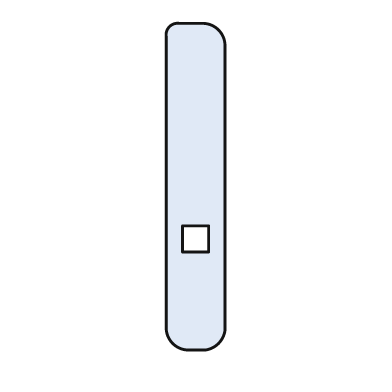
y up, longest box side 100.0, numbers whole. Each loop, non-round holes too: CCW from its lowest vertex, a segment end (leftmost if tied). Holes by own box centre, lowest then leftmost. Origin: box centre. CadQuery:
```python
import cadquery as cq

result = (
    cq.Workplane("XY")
    .moveTo(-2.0, -50.0)
    .lineTo(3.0, -50.0)
    .threePointArc((7.0, -48.0), (9.0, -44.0))
    .lineTo(9.0, 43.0)
    .threePointArc((7.0, 48.0), (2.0, 50.0))
    .lineTo(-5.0, 50.0)
    .threePointArc((-8.0, 49.0), (-9.0, 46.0))
    .lineTo(-9.0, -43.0)
    .threePointArc((-7.0, -48.0), (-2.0, -50.0))
    .close()
    .moveTo(-4.0, -20.0)
    .lineTo(4.0, -20.0)
    .lineTo(4.0, -12.0)
    .lineTo(-4.0, -12.0)
    .close()
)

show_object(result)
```